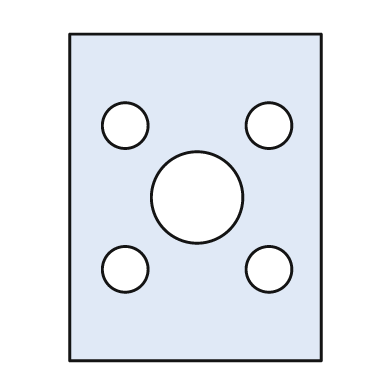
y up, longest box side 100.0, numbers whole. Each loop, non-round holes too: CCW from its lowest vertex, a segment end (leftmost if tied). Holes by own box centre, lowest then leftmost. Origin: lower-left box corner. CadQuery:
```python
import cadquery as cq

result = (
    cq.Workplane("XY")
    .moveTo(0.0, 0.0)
    .lineTo(77.0, 0.0)
    .lineTo(77.0, 100.0)
    .lineTo(0.0, 100.0)
    .close()
    .moveTo(17.0, 28.0)
    .circle(7.0)
    .moveTo(61.0, 28.0)
    .circle(7.0)
    .moveTo(39.0, 50.0)
    .circle(14.0)
    .moveTo(17.0, 72.0)
    .circle(7.0)
    .moveTo(61.0, 72.0)
    .circle(7.0)
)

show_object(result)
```